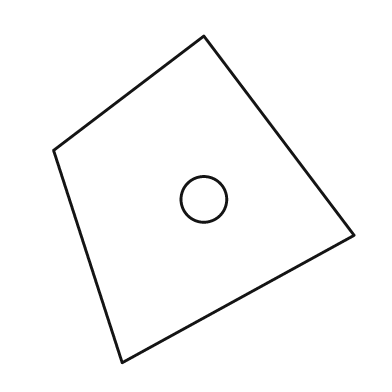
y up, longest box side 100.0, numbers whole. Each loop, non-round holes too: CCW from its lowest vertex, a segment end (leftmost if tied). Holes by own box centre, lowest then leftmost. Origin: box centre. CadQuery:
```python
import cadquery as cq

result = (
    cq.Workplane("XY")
    .moveTo(-25.0, -50.0)
    .lineTo(46.0, -11.0)
    .lineTo(0.0, 50.0)
    .lineTo(-46.0, 15.0)
    .close()
    .moveTo(0.0, 0.0)
    .circle(7.0)
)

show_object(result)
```